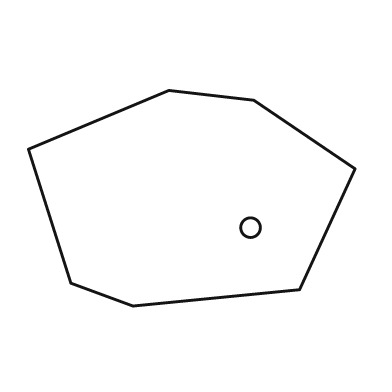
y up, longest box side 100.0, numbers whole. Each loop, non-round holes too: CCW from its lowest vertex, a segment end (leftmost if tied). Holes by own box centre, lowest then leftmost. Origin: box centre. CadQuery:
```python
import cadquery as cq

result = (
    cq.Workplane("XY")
    .moveTo(-18.0, -33.0)
    .lineTo(33.0, -28.0)
    .lineTo(50.0, 9.0)
    .lineTo(19.0, 30.0)
    .lineTo(-7.0, 33.0)
    .lineTo(-50.0, 15.0)
    .lineTo(-37.0, -26.0)
    .close()
    .moveTo(18.0, -9.0)
    .circle(3.0)
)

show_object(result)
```